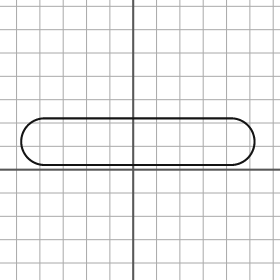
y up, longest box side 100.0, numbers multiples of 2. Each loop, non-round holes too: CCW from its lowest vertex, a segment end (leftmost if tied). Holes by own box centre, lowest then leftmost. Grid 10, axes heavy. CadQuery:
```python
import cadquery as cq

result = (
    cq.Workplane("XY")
    .moveTo(-38.0, 2.0)
    .lineTo(42.0, 2.0)
    .threePointArc((52.0, 12.0), (42.0, 22.0))
    .lineTo(-38.0, 22.0)
    .threePointArc((-48.0, 12.0), (-38.0, 2.0))
    .close()
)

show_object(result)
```